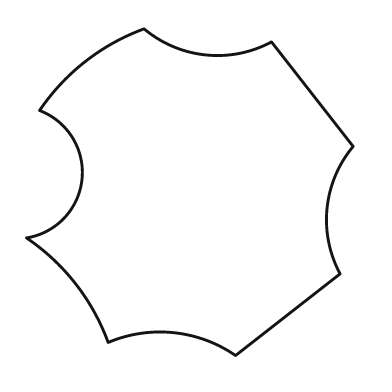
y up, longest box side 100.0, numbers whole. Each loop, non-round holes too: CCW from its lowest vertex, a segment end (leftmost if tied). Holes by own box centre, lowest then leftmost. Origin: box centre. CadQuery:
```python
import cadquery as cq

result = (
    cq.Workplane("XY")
    .moveTo(14.0, -50.0)
    .lineTo(46.0, -25.0)
    .threePointArc((42.0, -5.0), (50.0, 14.0))
    .lineTo(25.0, 46.0)
    .threePointArc((5.0, 42.0), (-14.0, 50.0))
    .threePointArc((-32.0, 40.0), (-46.0, 25.0))
    .threePointArc((-33.0, 4.0), (-50.0, -14.0))
    .threePointArc((-35.0, -28.0), (-25.0, -46.0))
    .threePointArc((-5.0, -43.0), (14.0, -50.0))
    .close()
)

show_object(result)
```